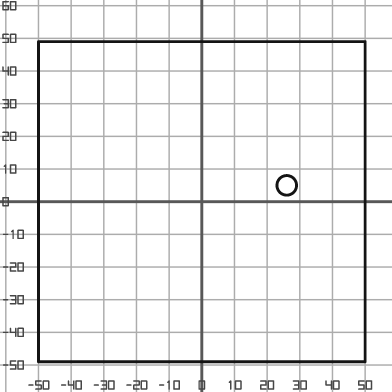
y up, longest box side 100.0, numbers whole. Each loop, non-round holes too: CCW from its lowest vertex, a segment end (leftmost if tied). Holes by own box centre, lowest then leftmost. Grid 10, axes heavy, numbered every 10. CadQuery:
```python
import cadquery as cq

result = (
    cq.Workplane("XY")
    .moveTo(-50.0, -49.0)
    .lineTo(50.0, -49.0)
    .lineTo(50.0, 49.0)
    .lineTo(-50.0, 49.0)
    .close()
    .moveTo(26.0, 5.0)
    .circle(3.0)
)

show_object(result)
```